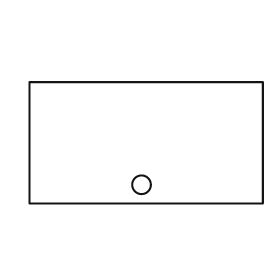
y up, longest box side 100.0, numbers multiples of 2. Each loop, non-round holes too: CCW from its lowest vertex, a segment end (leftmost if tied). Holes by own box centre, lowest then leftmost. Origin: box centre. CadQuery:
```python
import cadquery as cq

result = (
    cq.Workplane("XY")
    .moveTo(-50.0, -26.0)
    .lineTo(50.0, -26.0)
    .lineTo(50.0, 26.0)
    .lineTo(-50.0, 26.0)
    .close()
    .moveTo(-2.0, -18.0)
    .circle(4.0)
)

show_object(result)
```